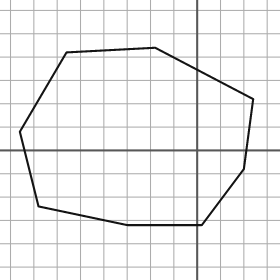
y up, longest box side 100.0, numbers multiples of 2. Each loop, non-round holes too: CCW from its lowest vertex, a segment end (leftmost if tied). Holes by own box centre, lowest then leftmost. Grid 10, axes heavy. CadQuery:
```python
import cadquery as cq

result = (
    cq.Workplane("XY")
    .moveTo(-30.0, -32.0)
    .lineTo(2.0, -32.0)
    .lineTo(20.0, -8.0)
    .lineTo(24.0, 22.0)
    .lineTo(-18.0, 44.0)
    .lineTo(-56.0, 42.0)
    .lineTo(-76.0, 8.0)
    .lineTo(-68.0, -24.0)
    .close()
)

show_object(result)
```